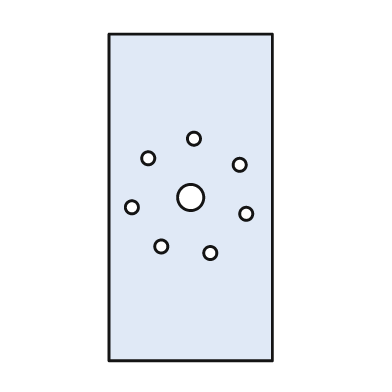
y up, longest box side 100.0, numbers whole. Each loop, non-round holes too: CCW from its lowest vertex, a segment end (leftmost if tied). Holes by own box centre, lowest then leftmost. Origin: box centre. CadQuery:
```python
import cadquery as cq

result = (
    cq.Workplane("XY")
    .moveTo(-25.0, -50.0)
    .lineTo(25.0, -50.0)
    .lineTo(25.0, 50.0)
    .lineTo(-25.0, 50.0)
    .close()
    .moveTo(6.0, -17.0)
    .circle(2.0)
    .moveTo(-9.0, -15.0)
    .circle(2.0)
    .moveTo(17.0, -5.0)
    .circle(2.0)
    .moveTo(-18.0, -3.0)
    .circle(2.0)
    .moveTo(0.0, 0.0)
    .circle(4.0)
    .moveTo(15.0, 10.0)
    .circle(2.0)
    .moveTo(-13.0, 12.0)
    .circle(2.0)
    .moveTo(1.0, 18.0)
    .circle(2.0)
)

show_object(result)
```